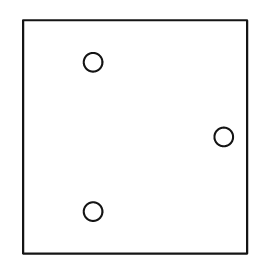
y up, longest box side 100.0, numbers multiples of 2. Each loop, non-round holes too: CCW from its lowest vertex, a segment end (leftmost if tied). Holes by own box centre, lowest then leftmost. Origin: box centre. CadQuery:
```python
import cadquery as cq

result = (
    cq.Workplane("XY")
    .moveTo(-48.0, -50.0)
    .lineTo(48.0, -50.0)
    .lineTo(48.0, 50.0)
    .lineTo(-48.0, 50.0)
    .close()
    .moveTo(-18.0, -32.0)
    .circle(4.0)
    .moveTo(38.0, 0.0)
    .circle(4.0)
    .moveTo(-18.0, 32.0)
    .circle(4.0)
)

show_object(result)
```